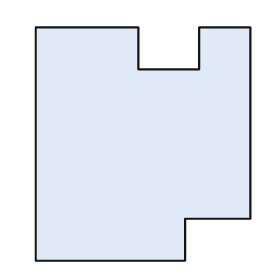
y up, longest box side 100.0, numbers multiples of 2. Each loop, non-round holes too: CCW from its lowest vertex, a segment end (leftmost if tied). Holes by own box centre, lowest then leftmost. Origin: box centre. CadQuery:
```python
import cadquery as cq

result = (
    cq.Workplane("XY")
    .moveTo(-46.0, -50.0)
    .lineTo(18.0, -50.0)
    .lineTo(18.0, -32.0)
    .lineTo(46.0, -32.0)
    .lineTo(46.0, 50.0)
    .lineTo(24.0, 50.0)
    .lineTo(24.0, 32.0)
    .lineTo(-2.0, 32.0)
    .lineTo(-2.0, 50.0)
    .lineTo(-46.0, 50.0)
    .close()
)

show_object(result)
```